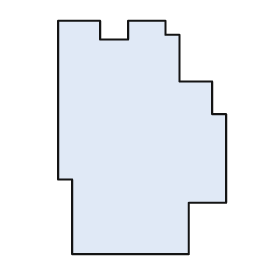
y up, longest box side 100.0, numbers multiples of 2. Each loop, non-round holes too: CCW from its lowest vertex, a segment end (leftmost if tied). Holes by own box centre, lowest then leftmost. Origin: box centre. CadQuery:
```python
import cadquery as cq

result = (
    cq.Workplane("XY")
    .moveTo(-30.0, -50.0)
    .lineTo(20.0, -50.0)
    .lineTo(20.0, -28.0)
    .lineTo(36.0, -28.0)
    .lineTo(36.0, 10.0)
    .lineTo(30.0, 10.0)
    .lineTo(30.0, 24.0)
    .lineTo(16.0, 24.0)
    .lineTo(16.0, 44.0)
    .lineTo(10.0, 44.0)
    .lineTo(10.0, 50.0)
    .lineTo(-6.0, 50.0)
    .lineTo(-6.0, 42.0)
    .lineTo(-18.0, 42.0)
    .lineTo(-18.0, 50.0)
    .lineTo(-36.0, 50.0)
    .lineTo(-36.0, -18.0)
    .lineTo(-30.0, -18.0)
    .close()
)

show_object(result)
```